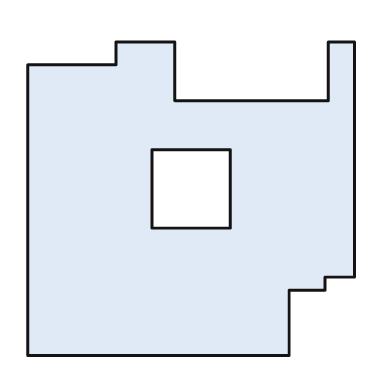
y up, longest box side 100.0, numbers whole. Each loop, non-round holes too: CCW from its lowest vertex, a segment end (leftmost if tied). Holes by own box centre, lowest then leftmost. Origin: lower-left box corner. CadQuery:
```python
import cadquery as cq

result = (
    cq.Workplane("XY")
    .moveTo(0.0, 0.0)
    .lineTo(80.0, 0.0)
    .lineTo(80.0, 20.0)
    .lineTo(91.0, 20.0)
    .lineTo(91.0, 24.0)
    .lineTo(100.0, 24.0)
    .lineTo(100.0, 96.0)
    .lineTo(92.0, 96.0)
    .lineTo(92.0, 78.0)
    .lineTo(45.0, 78.0)
    .lineTo(45.0, 96.0)
    .lineTo(27.0, 96.0)
    .lineTo(27.0, 89.0)
    .lineTo(0.0, 89.0)
    .close()
    .moveTo(38.0, 39.0)
    .lineTo(62.0, 39.0)
    .lineTo(62.0, 63.0)
    .lineTo(38.0, 63.0)
    .close()
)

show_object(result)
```